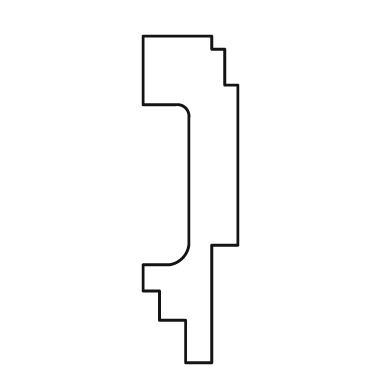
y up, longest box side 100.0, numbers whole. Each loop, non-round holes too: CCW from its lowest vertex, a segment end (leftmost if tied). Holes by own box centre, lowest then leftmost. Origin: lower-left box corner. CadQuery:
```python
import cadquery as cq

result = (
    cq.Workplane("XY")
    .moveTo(13.0, 0.0)
    .lineTo(21.0, 0.0)
    .lineTo(21.0, 36.0)
    .lineTo(29.0, 36.0)
    .lineTo(29.0, 85.0)
    .lineTo(25.0, 85.0)
    .lineTo(25.0, 96.0)
    .lineTo(21.0, 96.0)
    .lineTo(21.0, 100.0)
    .lineTo(0.0, 100.0)
    .lineTo(0.0, 79.0)
    .lineTo(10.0, 79.0)
    .threePointArc((13.0, 78.0), (14.0, 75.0))
    .lineTo(14.0, 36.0)
    .threePointArc((12.0, 32.0), (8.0, 30.0))
    .lineTo(0.0, 30.0)
    .lineTo(0.0, 22.0)
    .lineTo(5.0, 22.0)
    .lineTo(5.0, 13.0)
    .lineTo(13.0, 13.0)
    .close()
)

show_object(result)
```